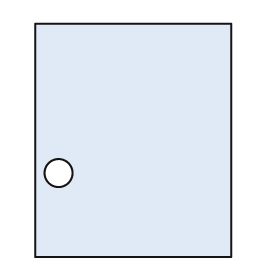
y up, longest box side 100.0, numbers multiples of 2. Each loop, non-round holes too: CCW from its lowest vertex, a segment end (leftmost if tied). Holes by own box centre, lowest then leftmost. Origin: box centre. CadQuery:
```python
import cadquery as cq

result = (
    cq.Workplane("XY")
    .moveTo(-42.0, -50.0)
    .lineTo(42.0, -50.0)
    .lineTo(42.0, 50.0)
    .lineTo(-42.0, 50.0)
    .close()
    .moveTo(-32.0, -14.0)
    .circle(6.0)
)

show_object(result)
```